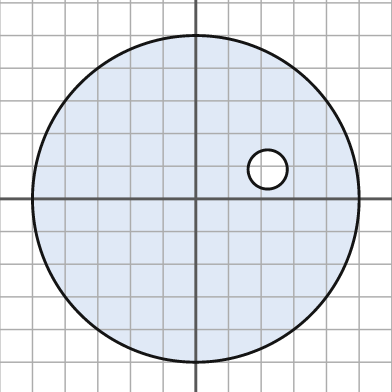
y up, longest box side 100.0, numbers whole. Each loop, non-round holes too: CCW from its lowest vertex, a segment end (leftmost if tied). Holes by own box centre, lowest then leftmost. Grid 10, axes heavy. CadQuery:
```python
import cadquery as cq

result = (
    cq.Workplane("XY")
    .moveTo(0.0, 0.0)
    .circle(50.0)
    .moveTo(22.0, 9.0)
    .circle(6.0)
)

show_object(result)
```